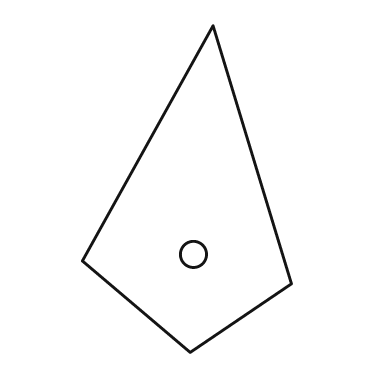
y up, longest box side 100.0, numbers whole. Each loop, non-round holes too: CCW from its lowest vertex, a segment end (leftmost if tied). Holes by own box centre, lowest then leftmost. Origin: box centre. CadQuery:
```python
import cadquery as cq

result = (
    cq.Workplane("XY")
    .moveTo(1.0, -50.0)
    .lineTo(32.0, -29.0)
    .lineTo(8.0, 50.0)
    .lineTo(-32.0, -22.0)
    .close()
    .moveTo(2.0, -20.0)
    .circle(4.0)
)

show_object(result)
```